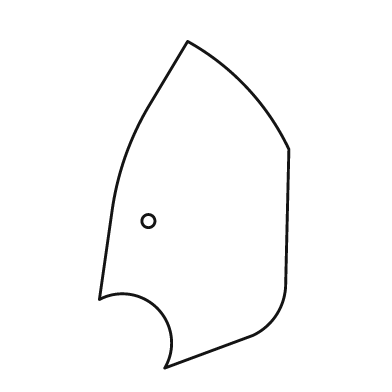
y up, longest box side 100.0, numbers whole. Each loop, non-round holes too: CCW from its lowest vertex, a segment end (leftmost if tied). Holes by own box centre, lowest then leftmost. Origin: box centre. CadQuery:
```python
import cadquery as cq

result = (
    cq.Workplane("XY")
    .moveTo(-9.0, -50.0)
    .lineTo(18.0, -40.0)
    .threePointArc((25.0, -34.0), (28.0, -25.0))
    .lineTo(29.0, 17.0)
    .threePointArc((16.0, 36.0), (-2.0, 50.0))
    .lineTo(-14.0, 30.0)
    .threePointArc((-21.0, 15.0), (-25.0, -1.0))
    .lineTo(-29.0, -29.0)
    .threePointArc((-11.0, -32.0), (-9.0, -50.0))
    .close()
    .moveTo(-14.0, -5.0)
    .circle(2.0)
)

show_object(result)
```